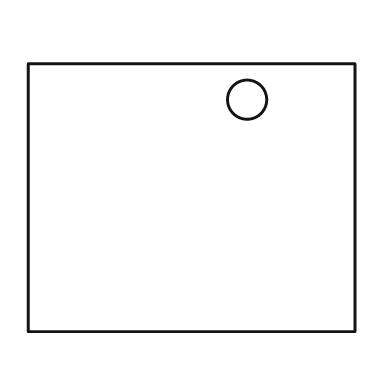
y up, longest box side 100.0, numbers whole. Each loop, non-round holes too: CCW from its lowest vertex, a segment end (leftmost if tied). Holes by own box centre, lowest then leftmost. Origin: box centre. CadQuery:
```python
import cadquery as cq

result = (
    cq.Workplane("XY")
    .moveTo(-50.0, -41.0)
    .lineTo(50.0, -41.0)
    .lineTo(50.0, 41.0)
    .lineTo(-50.0, 41.0)
    .close()
    .moveTo(17.0, 30.0)
    .circle(6.0)
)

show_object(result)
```